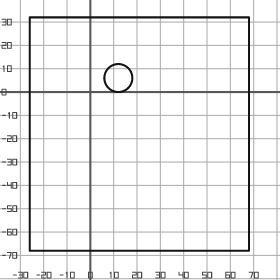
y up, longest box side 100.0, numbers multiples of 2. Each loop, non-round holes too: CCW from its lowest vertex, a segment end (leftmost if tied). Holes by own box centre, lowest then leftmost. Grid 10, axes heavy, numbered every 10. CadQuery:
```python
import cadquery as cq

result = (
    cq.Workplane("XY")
    .moveTo(-26.0, -68.0)
    .lineTo(68.0, -68.0)
    .lineTo(68.0, 32.0)
    .lineTo(-26.0, 32.0)
    .close()
    .moveTo(12.0, 6.0)
    .circle(6.0)
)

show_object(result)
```